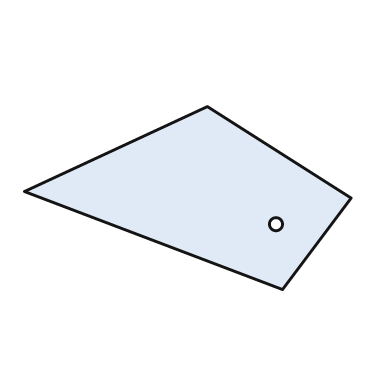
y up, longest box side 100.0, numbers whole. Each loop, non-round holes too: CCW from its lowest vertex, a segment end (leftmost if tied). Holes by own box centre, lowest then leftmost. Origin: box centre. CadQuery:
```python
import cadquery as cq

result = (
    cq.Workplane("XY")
    .moveTo(29.0, -28.0)
    .lineTo(50.0, 0.0)
    .lineTo(6.0, 28.0)
    .lineTo(-50.0, 2.0)
    .close()
    .moveTo(27.0, -8.0)
    .circle(2.0)
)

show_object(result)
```